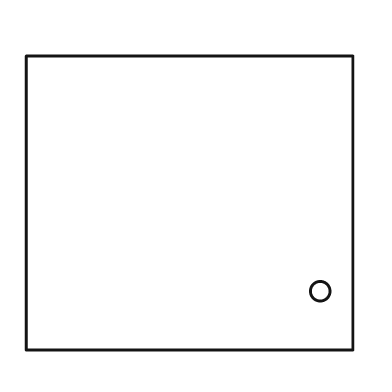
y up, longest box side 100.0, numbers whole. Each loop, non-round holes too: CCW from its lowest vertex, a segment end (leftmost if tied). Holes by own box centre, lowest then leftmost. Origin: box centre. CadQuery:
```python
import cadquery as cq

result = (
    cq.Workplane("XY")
    .moveTo(-50.0, -45.0)
    .lineTo(50.0, -45.0)
    .lineTo(50.0, 45.0)
    .lineTo(-50.0, 45.0)
    .close()
    .moveTo(40.0, -27.0)
    .circle(3.0)
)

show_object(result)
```